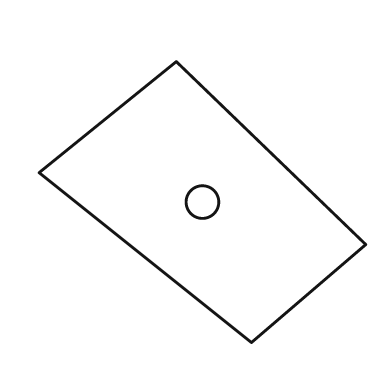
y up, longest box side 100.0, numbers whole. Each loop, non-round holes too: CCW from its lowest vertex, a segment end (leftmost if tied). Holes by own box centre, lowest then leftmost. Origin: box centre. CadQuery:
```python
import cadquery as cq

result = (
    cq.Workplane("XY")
    .moveTo(15.0, -43.0)
    .lineTo(50.0, -13.0)
    .lineTo(-8.0, 43.0)
    .lineTo(-50.0, 9.0)
    .close()
    .moveTo(0.0, 0.0)
    .circle(5.0)
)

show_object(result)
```